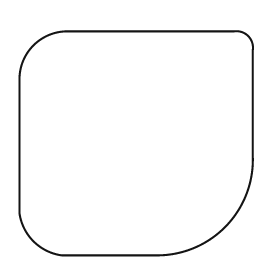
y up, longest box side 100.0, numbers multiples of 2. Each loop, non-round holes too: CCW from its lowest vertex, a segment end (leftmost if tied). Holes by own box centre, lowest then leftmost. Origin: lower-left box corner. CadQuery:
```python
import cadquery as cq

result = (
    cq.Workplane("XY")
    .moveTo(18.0, 0.0)
    .lineTo(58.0, 0.0)
    .threePointArc((88.0, 12.0), (100.0, 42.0))
    .lineTo(100.0, 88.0)
    .threePointArc((98.0, 94.0), (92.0, 96.0))
    .lineTo(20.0, 96.0)
    .threePointArc((6.0, 90.0), (0.0, 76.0))
    .lineTo(0.0, 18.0)
    .threePointArc((6.0, 6.0), (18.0, 0.0))
    .close()
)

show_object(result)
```